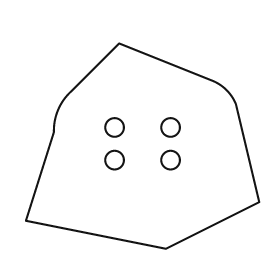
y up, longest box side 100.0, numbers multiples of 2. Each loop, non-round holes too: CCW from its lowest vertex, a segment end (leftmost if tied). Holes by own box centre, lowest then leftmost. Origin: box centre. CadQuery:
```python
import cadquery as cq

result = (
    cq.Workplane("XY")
    .moveTo(10.0, -44.0)
    .lineTo(50.0, -24.0)
    .lineTo(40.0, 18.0)
    .threePointArc((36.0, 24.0), (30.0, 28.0))
    .lineTo(-10.0, 44.0)
    .lineTo(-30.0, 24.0)
    .threePointArc((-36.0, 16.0), (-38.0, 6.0))
    .lineTo(-50.0, -32.0)
    .close()
    .moveTo(-12.0, -6.0)
    .circle(4.0)
    .moveTo(12.0, -6.0)
    .circle(4.0)
    .moveTo(-12.0, 8.0)
    .circle(4.0)
    .moveTo(12.0, 8.0)
    .circle(4.0)
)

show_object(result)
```